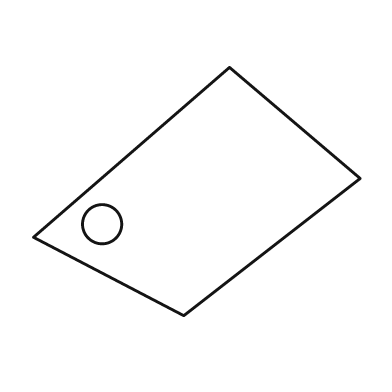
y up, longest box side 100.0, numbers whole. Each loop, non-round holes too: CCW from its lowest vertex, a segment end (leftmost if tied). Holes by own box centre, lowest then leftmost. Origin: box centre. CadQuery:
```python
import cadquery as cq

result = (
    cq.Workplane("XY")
    .moveTo(-4.0, -38.0)
    .lineTo(50.0, 4.0)
    .lineTo(10.0, 38.0)
    .lineTo(-50.0, -14.0)
    .close()
    .moveTo(-29.0, -10.0)
    .circle(6.0)
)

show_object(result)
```